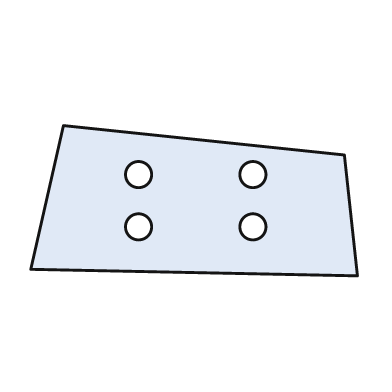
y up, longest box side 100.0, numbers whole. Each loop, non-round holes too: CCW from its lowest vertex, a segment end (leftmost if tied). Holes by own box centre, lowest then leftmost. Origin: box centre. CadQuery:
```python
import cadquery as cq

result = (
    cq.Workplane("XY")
    .moveTo(50.0, -23.0)
    .lineTo(46.0, 14.0)
    .lineTo(-40.0, 23.0)
    .lineTo(-50.0, -21.0)
    .close()
    .moveTo(-17.0, -8.0)
    .circle(4.0)
    .moveTo(18.0, -8.0)
    .circle(4.0)
    .moveTo(-17.0, 8.0)
    .circle(4.0)
    .moveTo(18.0, 8.0)
    .circle(4.0)
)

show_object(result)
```